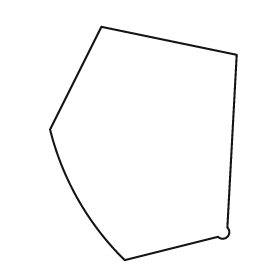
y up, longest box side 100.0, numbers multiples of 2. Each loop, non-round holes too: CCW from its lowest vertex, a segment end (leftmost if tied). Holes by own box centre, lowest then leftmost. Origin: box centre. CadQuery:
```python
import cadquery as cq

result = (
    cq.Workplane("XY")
    .moveTo(-8.0, -50.0)
    .lineTo(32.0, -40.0)
    .threePointArc((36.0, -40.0), (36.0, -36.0))
    .lineTo(40.0, 38.0)
    .lineTo(-18.0, 50.0)
    .lineTo(-40.0, 6.0)
    .threePointArc((-28.0, -24.0), (-8.0, -50.0))
    .close()
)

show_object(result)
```